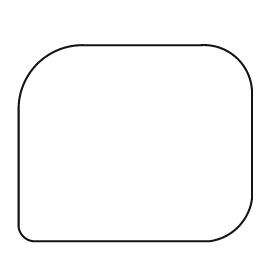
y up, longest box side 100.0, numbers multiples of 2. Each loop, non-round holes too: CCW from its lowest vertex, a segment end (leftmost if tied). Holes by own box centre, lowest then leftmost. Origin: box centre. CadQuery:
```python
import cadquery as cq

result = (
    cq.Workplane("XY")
    .moveTo(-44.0, -42.0)
    .lineTo(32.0, -42.0)
    .threePointArc((44.0, -36.0), (50.0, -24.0))
    .lineTo(50.0, 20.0)
    .threePointArc((44.0, 36.0), (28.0, 42.0))
    .lineTo(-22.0, 42.0)
    .threePointArc((-42.0, 34.0), (-50.0, 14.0))
    .lineTo(-50.0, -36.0)
    .threePointArc((-48.0, -40.0), (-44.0, -42.0))
    .close()
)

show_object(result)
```